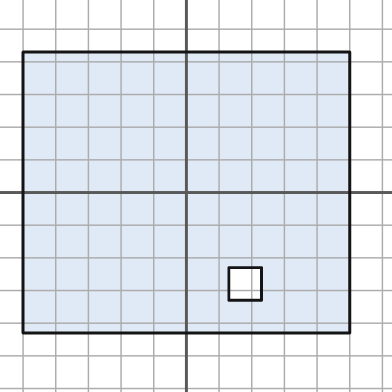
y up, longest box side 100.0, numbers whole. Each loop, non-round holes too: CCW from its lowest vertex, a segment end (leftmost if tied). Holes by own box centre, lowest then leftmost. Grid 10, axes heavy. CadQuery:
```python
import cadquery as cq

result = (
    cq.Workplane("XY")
    .moveTo(-50.0, -43.0)
    .lineTo(50.0, -43.0)
    .lineTo(50.0, 43.0)
    .lineTo(-50.0, 43.0)
    .close()
    .moveTo(13.0, -33.0)
    .lineTo(23.0, -33.0)
    .lineTo(23.0, -23.0)
    .lineTo(13.0, -23.0)
    .close()
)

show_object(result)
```